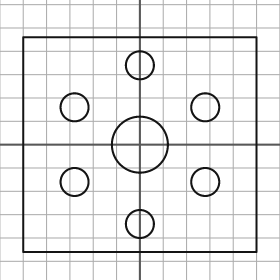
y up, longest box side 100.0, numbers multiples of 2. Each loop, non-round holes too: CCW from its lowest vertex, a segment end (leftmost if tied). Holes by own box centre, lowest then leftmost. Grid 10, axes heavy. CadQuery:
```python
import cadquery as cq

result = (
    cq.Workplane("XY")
    .moveTo(-50.0, -46.0)
    .lineTo(50.0, -46.0)
    .lineTo(50.0, 46.0)
    .lineTo(-50.0, 46.0)
    .close()
    .moveTo(0.0, -34.0)
    .circle(6.0)
    .moveTo(-28.0, -16.0)
    .circle(6.0)
    .moveTo(28.0, -16.0)
    .circle(6.0)
    .moveTo(0.0, 0.0)
    .circle(12.0)
    .moveTo(-28.0, 16.0)
    .circle(6.0)
    .moveTo(28.0, 16.0)
    .circle(6.0)
    .moveTo(0.0, 34.0)
    .circle(6.0)
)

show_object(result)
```